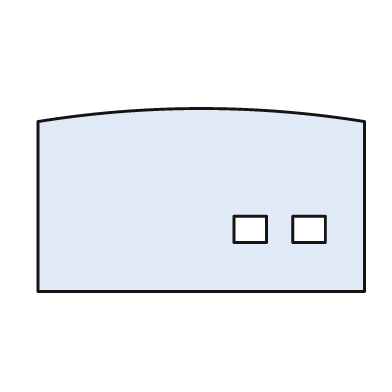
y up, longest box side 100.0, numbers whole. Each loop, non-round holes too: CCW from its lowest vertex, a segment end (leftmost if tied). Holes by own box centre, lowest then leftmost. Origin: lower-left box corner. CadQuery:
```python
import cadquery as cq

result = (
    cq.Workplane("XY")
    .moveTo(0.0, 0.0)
    .lineTo(100.0, 0.0)
    .lineTo(100.0, 52.0)
    .threePointArc((50.0, 56.0), (0.0, 52.0))
    .close()
    .moveTo(60.0, 15.0)
    .lineTo(70.0, 15.0)
    .lineTo(70.0, 23.0)
    .lineTo(60.0, 23.0)
    .close()
    .moveTo(78.0, 15.0)
    .lineTo(88.0, 15.0)
    .lineTo(88.0, 23.0)
    .lineTo(78.0, 23.0)
    .close()
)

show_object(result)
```